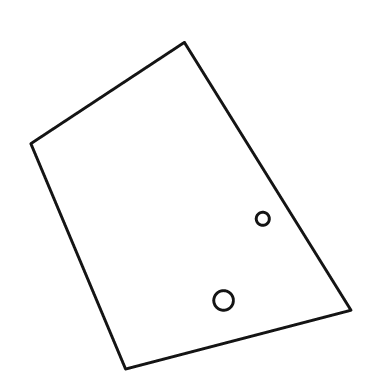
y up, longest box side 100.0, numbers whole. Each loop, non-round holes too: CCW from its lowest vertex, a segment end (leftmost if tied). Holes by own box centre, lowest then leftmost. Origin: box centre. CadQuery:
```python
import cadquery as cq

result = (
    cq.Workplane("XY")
    .moveTo(-20.0, -50.0)
    .lineTo(49.0, -32.0)
    .lineTo(-2.0, 50.0)
    .lineTo(-49.0, 19.0)
    .close()
    .moveTo(10.0, -29.0)
    .circle(3.0)
    .moveTo(22.0, -4.0)
    .circle(2.0)
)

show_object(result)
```